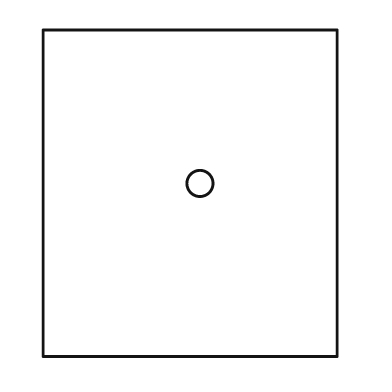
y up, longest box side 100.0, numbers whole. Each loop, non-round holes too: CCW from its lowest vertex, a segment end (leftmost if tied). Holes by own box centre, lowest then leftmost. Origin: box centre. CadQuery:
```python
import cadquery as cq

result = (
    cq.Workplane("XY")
    .moveTo(-45.0, -50.0)
    .lineTo(45.0, -50.0)
    .lineTo(45.0, 50.0)
    .lineTo(-45.0, 50.0)
    .close()
    .moveTo(3.0, 3.0)
    .circle(4.0)
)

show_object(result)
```